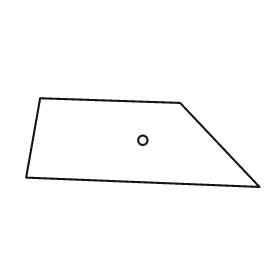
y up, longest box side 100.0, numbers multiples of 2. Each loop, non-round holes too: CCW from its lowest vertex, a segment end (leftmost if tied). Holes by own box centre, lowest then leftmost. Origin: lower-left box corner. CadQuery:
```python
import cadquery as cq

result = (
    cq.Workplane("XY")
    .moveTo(100.0, 0.0)
    .lineTo(66.0, 36.0)
    .lineTo(6.0, 38.0)
    .lineTo(0.0, 4.0)
    .close()
    .moveTo(50.0, 20.0)
    .circle(2.0)
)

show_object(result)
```